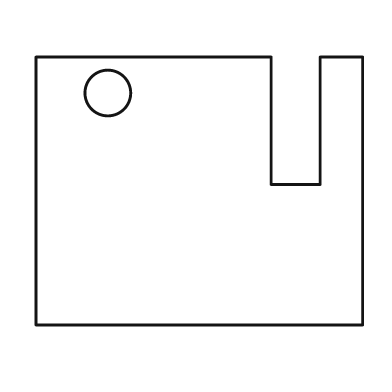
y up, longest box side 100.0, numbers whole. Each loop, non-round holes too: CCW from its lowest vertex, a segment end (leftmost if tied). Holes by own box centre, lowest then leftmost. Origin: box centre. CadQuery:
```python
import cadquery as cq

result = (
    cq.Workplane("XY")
    .moveTo(-50.0, -41.0)
    .lineTo(50.0, -41.0)
    .lineTo(50.0, 41.0)
    .lineTo(37.0, 41.0)
    .lineTo(37.0, 2.0)
    .lineTo(22.0, 2.0)
    .lineTo(22.0, 41.0)
    .lineTo(-50.0, 41.0)
    .close()
    .moveTo(-28.0, 30.0)
    .circle(7.0)
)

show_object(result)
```